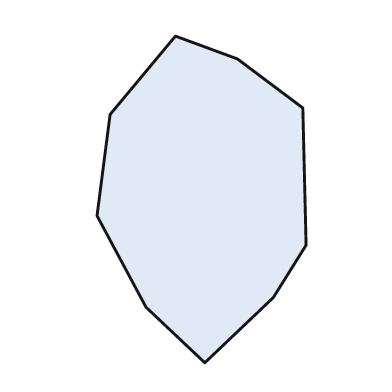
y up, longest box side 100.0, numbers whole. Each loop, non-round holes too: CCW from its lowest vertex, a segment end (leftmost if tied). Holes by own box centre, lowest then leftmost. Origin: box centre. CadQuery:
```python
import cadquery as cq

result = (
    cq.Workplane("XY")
    .moveTo(1.0, -50.0)
    .lineTo(22.0, -30.0)
    .lineTo(32.0, -14.0)
    .lineTo(31.0, 28.0)
    .lineTo(11.0, 43.0)
    .lineTo(-8.0, 50.0)
    .lineTo(-28.0, 26.0)
    .lineTo(-32.0, -5.0)
    .lineTo(-17.0, -33.0)
    .close()
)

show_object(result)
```